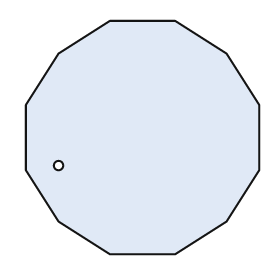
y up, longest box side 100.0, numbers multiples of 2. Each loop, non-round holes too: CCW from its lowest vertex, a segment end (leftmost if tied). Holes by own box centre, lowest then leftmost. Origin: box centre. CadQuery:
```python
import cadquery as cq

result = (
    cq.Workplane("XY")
    .moveTo(-14.0, -50.0)
    .lineTo(14.0, -50.0)
    .lineTo(36.0, -36.0)
    .lineTo(50.0, -14.0)
    .lineTo(50.0, 14.0)
    .lineTo(36.0, 36.0)
    .lineTo(14.0, 50.0)
    .lineTo(-14.0, 50.0)
    .lineTo(-36.0, 36.0)
    .lineTo(-50.0, 14.0)
    .lineTo(-50.0, -14.0)
    .lineTo(-36.0, -36.0)
    .close()
    .moveTo(-36.0, -12.0)
    .circle(2.0)
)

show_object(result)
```